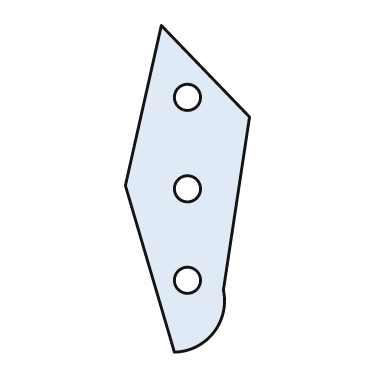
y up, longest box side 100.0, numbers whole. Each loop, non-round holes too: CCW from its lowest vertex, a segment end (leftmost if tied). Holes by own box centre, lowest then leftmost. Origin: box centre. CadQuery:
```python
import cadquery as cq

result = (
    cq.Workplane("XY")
    .moveTo(-4.0, -50.0)
    .threePointArc((8.0, -44.0), (11.0, -31.0))
    .lineTo(19.0, 22.0)
    .lineTo(-8.0, 50.0)
    .lineTo(-19.0, 1.0)
    .close()
    .moveTo(0.0, -28.0)
    .circle(4.0)
    .moveTo(0.0, 0.0)
    .circle(4.0)
    .moveTo(0.0, 28.0)
    .circle(4.0)
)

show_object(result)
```